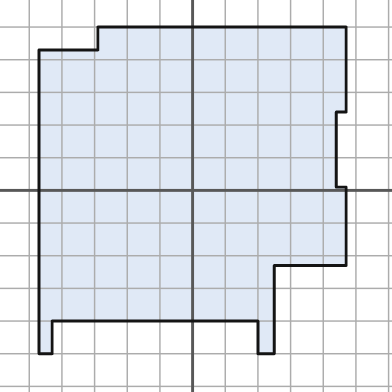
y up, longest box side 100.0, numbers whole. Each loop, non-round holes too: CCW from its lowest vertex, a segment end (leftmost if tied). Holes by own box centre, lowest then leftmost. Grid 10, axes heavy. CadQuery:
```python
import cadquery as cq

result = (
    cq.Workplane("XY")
    .moveTo(-47.0, -50.0)
    .lineTo(-43.0, -50.0)
    .lineTo(-43.0, -40.0)
    .lineTo(20.0, -40.0)
    .lineTo(20.0, -50.0)
    .lineTo(25.0, -50.0)
    .lineTo(25.0, -23.0)
    .lineTo(47.0, -23.0)
    .lineTo(47.0, 1.0)
    .lineTo(44.0, 1.0)
    .lineTo(44.0, 24.0)
    .lineTo(47.0, 24.0)
    .lineTo(47.0, 50.0)
    .lineTo(-29.0, 50.0)
    .lineTo(-29.0, 43.0)
    .lineTo(-47.0, 43.0)
    .close()
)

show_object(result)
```